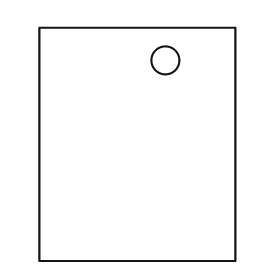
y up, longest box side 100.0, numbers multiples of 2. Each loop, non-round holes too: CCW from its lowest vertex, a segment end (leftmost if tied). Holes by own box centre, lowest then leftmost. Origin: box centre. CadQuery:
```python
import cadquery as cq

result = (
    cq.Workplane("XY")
    .moveTo(-42.0, -50.0)
    .lineTo(42.0, -50.0)
    .lineTo(42.0, 50.0)
    .lineTo(-42.0, 50.0)
    .close()
    .moveTo(12.0, 36.0)
    .circle(6.0)
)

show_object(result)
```